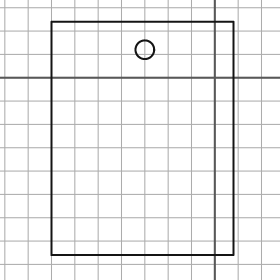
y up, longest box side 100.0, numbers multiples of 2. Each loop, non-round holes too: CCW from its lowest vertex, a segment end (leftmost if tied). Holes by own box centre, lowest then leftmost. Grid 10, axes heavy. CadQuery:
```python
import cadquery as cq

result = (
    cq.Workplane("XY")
    .moveTo(-70.0, -76.0)
    .lineTo(8.0, -76.0)
    .lineTo(8.0, 24.0)
    .lineTo(-70.0, 24.0)
    .close()
    .moveTo(-30.0, 12.0)
    .circle(4.0)
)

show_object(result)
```